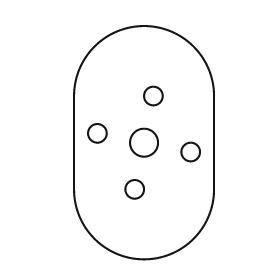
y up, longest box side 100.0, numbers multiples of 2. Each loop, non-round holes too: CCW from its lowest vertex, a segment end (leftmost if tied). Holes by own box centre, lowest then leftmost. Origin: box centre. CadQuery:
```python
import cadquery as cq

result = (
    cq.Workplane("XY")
    .moveTo(-30.0, -20.0)
    .threePointArc((0.0, -50.0), (30.0, -20.0))
    .lineTo(30.0, 20.0)
    .threePointArc((0.0, 50.0), (-30.0, 20.0))
    .close()
    .moveTo(-4.0, -20.0)
    .circle(4.0)
    .moveTo(20.0, -4.0)
    .circle(4.0)
    .moveTo(0.0, 0.0)
    .circle(6.0)
    .moveTo(-20.0, 4.0)
    .circle(4.0)
    .moveTo(4.0, 20.0)
    .circle(4.0)
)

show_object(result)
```